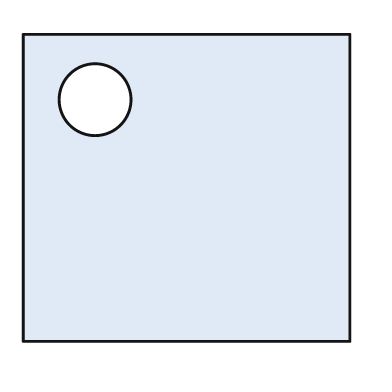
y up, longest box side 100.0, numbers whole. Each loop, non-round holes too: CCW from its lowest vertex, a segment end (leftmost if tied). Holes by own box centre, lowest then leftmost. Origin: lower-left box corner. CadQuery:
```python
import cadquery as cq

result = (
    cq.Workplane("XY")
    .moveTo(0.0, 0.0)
    .lineTo(100.0, 0.0)
    .lineTo(100.0, 94.0)
    .lineTo(0.0, 94.0)
    .close()
    .moveTo(22.0, 74.0)
    .circle(11.0)
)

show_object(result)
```